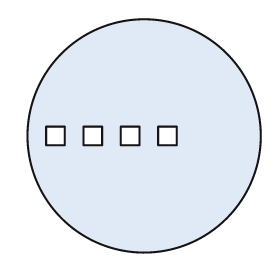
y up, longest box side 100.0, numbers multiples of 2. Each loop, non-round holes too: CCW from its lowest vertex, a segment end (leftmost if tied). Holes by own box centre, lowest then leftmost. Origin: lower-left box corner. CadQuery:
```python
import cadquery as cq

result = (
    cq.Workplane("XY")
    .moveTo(50.0, 50.0)
    .circle(50.0)
    .moveTo(8.0, 46.0)
    .lineTo(16.0, 46.0)
    .lineTo(16.0, 54.0)
    .lineTo(8.0, 54.0)
    .close()
    .moveTo(24.0, 46.0)
    .lineTo(32.0, 46.0)
    .lineTo(32.0, 54.0)
    .lineTo(24.0, 54.0)
    .close()
    .moveTo(40.0, 46.0)
    .lineTo(48.0, 46.0)
    .lineTo(48.0, 54.0)
    .lineTo(40.0, 54.0)
    .close()
    .moveTo(56.0, 46.0)
    .lineTo(64.0, 46.0)
    .lineTo(64.0, 54.0)
    .lineTo(56.0, 54.0)
    .close()
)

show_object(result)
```